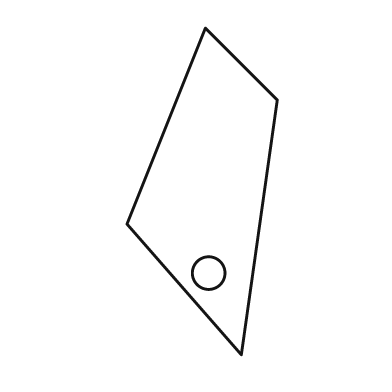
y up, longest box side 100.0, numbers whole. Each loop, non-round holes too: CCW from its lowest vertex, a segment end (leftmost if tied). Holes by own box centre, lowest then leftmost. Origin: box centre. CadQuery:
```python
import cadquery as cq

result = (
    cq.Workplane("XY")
    .moveTo(12.0, -50.0)
    .lineTo(23.0, 28.0)
    .lineTo(1.0, 50.0)
    .lineTo(-23.0, -10.0)
    .close()
    .moveTo(2.0, -25.0)
    .circle(5.0)
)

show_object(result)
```